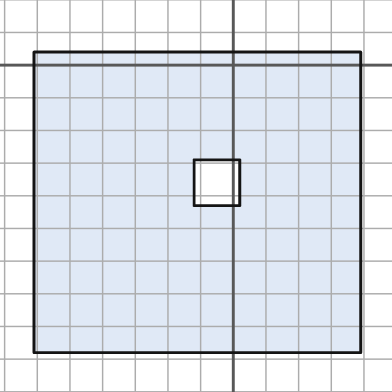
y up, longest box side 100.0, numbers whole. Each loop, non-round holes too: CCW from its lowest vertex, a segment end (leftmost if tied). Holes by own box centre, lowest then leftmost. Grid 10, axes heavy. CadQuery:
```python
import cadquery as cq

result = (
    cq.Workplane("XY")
    .moveTo(-61.0, -88.0)
    .lineTo(39.0, -88.0)
    .lineTo(39.0, 4.0)
    .lineTo(-61.0, 4.0)
    .close()
    .moveTo(-12.0, -43.0)
    .lineTo(2.0, -43.0)
    .lineTo(2.0, -29.0)
    .lineTo(-12.0, -29.0)
    .close()
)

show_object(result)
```